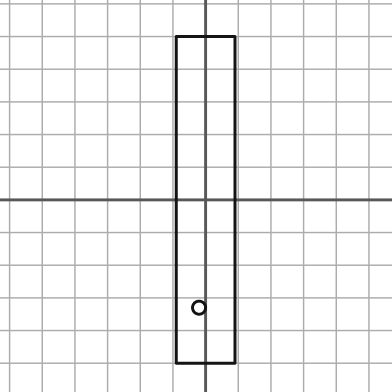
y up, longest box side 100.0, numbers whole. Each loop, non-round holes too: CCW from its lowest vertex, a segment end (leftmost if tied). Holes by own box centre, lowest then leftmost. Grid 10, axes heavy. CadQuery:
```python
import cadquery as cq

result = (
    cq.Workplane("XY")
    .moveTo(-9.0, -50.0)
    .lineTo(9.0, -50.0)
    .lineTo(9.0, 50.0)
    .lineTo(-9.0, 50.0)
    .close()
    .moveTo(-2.0, -33.0)
    .circle(2.0)
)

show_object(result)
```